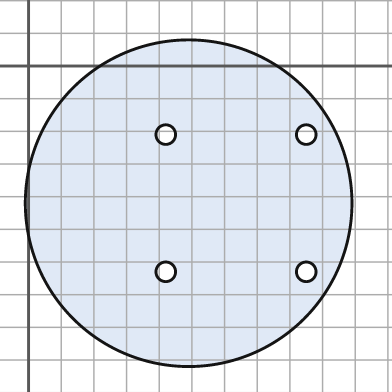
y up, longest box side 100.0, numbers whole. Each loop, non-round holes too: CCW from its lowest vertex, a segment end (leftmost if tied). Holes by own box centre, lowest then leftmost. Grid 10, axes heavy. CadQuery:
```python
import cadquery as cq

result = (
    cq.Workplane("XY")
    .moveTo(49.0, -42.0)
    .circle(50.0)
    .moveTo(42.0, -63.0)
    .circle(3.0)
    .moveTo(85.0, -63.0)
    .circle(3.0)
    .moveTo(42.0, -21.0)
    .circle(3.0)
    .moveTo(85.0, -21.0)
    .circle(3.0)
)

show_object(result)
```